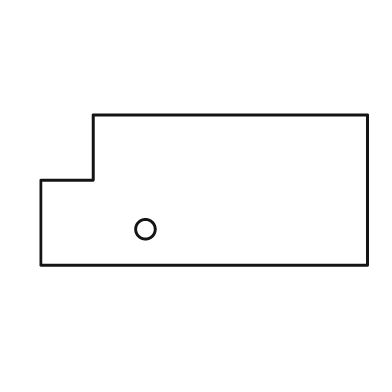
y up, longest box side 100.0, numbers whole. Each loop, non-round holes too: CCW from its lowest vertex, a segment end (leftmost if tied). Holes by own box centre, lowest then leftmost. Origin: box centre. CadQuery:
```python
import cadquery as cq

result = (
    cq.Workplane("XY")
    .moveTo(-50.0, -23.0)
    .lineTo(50.0, -23.0)
    .lineTo(50.0, 23.0)
    .lineTo(-34.0, 23.0)
    .lineTo(-34.0, 3.0)
    .lineTo(-50.0, 3.0)
    .close()
    .moveTo(-18.0, -12.0)
    .circle(3.0)
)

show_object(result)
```